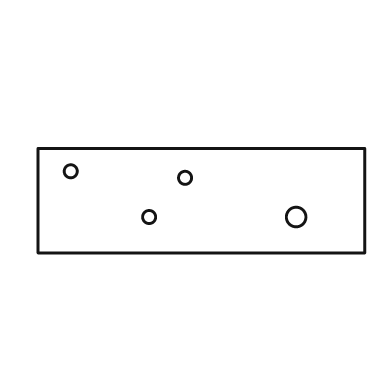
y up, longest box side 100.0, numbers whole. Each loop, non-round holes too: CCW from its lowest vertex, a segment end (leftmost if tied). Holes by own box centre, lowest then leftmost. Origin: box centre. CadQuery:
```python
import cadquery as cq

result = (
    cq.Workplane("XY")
    .moveTo(-50.0, -16.0)
    .lineTo(50.0, -16.0)
    .lineTo(50.0, 16.0)
    .lineTo(-50.0, 16.0)
    .close()
    .moveTo(-16.0, -5.0)
    .circle(2.0)
    .moveTo(29.0, -5.0)
    .circle(3.0)
    .moveTo(-5.0, 7.0)
    .circle(2.0)
    .moveTo(-40.0, 9.0)
    .circle(2.0)
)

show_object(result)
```